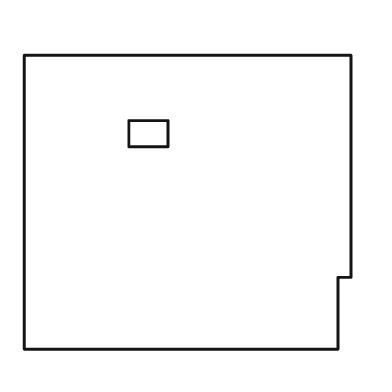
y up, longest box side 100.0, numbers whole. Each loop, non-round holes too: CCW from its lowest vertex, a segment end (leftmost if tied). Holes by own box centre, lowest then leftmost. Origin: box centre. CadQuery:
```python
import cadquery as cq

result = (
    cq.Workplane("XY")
    .moveTo(-50.0, -45.0)
    .lineTo(46.0, -45.0)
    .lineTo(46.0, -23.0)
    .lineTo(50.0, -23.0)
    .lineTo(50.0, 45.0)
    .lineTo(-50.0, 45.0)
    .close()
    .moveTo(-18.0, 17.0)
    .lineTo(-6.0, 17.0)
    .lineTo(-6.0, 25.0)
    .lineTo(-18.0, 25.0)
    .close()
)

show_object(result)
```